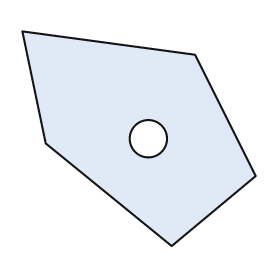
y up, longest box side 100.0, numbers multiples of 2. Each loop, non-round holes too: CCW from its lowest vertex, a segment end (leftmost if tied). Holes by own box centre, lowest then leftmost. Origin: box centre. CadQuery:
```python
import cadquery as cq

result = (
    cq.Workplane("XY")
    .moveTo(14.0, -46.0)
    .lineTo(50.0, -16.0)
    .lineTo(24.0, 36.0)
    .lineTo(-50.0, 46.0)
    .lineTo(-40.0, -2.0)
    .close()
    .moveTo(4.0, 0.0)
    .circle(8.0)
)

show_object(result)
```